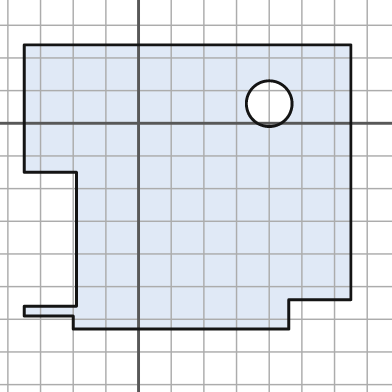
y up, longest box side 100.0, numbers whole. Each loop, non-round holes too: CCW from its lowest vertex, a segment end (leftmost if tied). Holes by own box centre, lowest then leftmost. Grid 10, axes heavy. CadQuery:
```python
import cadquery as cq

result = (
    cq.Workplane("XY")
    .moveTo(-20.0, -63.0)
    .lineTo(46.0, -63.0)
    .lineTo(46.0, -54.0)
    .lineTo(65.0, -54.0)
    .lineTo(65.0, 24.0)
    .lineTo(-35.0, 24.0)
    .lineTo(-35.0, -15.0)
    .lineTo(-19.0, -15.0)
    .lineTo(-19.0, -56.0)
    .lineTo(-35.0, -56.0)
    .lineTo(-35.0, -59.0)
    .lineTo(-20.0, -59.0)
    .close()
    .moveTo(40.0, 6.0)
    .circle(7.0)
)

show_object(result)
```